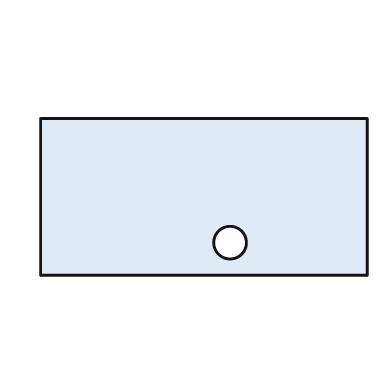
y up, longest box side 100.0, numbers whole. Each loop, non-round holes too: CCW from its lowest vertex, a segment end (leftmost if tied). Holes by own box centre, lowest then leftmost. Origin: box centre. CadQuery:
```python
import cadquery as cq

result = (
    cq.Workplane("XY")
    .moveTo(-50.0, -24.0)
    .lineTo(50.0, -24.0)
    .lineTo(50.0, 24.0)
    .lineTo(-50.0, 24.0)
    .close()
    .moveTo(8.0, -14.0)
    .circle(5.0)
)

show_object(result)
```